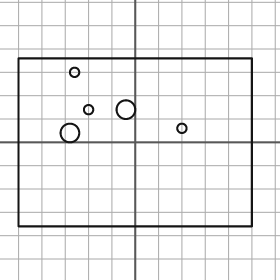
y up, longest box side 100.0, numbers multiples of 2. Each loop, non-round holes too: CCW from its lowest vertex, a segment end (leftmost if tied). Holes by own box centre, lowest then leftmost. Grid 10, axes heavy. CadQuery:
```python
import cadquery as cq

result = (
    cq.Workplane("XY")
    .moveTo(-50.0, -36.0)
    .lineTo(50.0, -36.0)
    .lineTo(50.0, 36.0)
    .lineTo(-50.0, 36.0)
    .close()
    .moveTo(-28.0, 4.0)
    .circle(4.0)
    .moveTo(20.0, 6.0)
    .circle(2.0)
    .moveTo(-20.0, 14.0)
    .circle(2.0)
    .moveTo(-4.0, 14.0)
    .circle(4.0)
    .moveTo(-26.0, 30.0)
    .circle(2.0)
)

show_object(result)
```